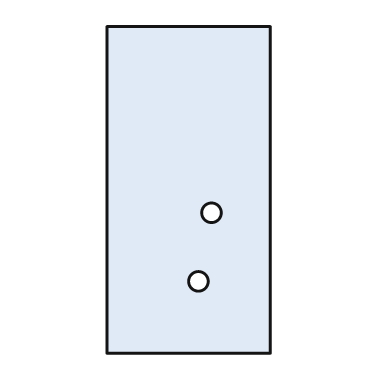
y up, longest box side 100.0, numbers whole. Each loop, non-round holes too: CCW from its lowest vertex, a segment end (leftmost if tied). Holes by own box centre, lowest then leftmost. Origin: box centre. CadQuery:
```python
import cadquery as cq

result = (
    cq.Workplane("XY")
    .moveTo(-25.0, -50.0)
    .lineTo(25.0, -50.0)
    .lineTo(25.0, 50.0)
    .lineTo(-25.0, 50.0)
    .close()
    .moveTo(3.0, -28.0)
    .circle(3.0)
    .moveTo(7.0, -7.0)
    .circle(3.0)
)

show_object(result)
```